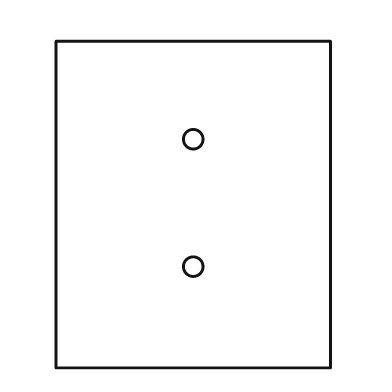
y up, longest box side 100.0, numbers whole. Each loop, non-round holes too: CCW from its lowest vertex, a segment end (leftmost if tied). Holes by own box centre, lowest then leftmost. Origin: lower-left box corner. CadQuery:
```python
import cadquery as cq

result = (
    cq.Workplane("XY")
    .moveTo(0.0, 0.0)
    .lineTo(84.0, 0.0)
    .lineTo(84.0, 100.0)
    .lineTo(0.0, 100.0)
    .close()
    .moveTo(42.0, 31.0)
    .circle(3.0)
    .moveTo(42.0, 70.0)
    .circle(3.0)
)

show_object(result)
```